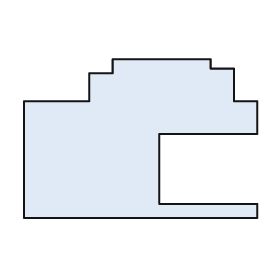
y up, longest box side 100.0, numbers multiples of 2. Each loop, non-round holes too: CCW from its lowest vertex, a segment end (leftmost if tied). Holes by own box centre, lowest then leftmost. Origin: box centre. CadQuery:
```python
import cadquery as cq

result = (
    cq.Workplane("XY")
    .moveTo(-50.0, -34.0)
    .lineTo(50.0, -34.0)
    .lineTo(50.0, -28.0)
    .lineTo(8.0, -28.0)
    .lineTo(8.0, 2.0)
    .lineTo(50.0, 2.0)
    .lineTo(50.0, 16.0)
    .lineTo(40.0, 16.0)
    .lineTo(40.0, 30.0)
    .lineTo(30.0, 30.0)
    .lineTo(30.0, 34.0)
    .lineTo(-12.0, 34.0)
    .lineTo(-12.0, 28.0)
    .lineTo(-22.0, 28.0)
    .lineTo(-22.0, 16.0)
    .lineTo(-50.0, 16.0)
    .close()
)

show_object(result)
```